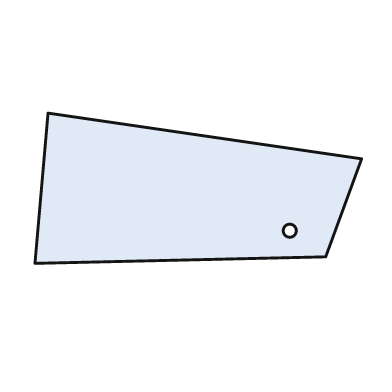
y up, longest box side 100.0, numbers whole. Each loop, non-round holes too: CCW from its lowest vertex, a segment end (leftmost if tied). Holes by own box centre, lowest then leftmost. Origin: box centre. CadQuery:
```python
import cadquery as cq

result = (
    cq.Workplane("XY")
    .moveTo(-50.0, -23.0)
    .lineTo(39.0, -21.0)
    .lineTo(50.0, 9.0)
    .lineTo(-46.0, 23.0)
    .close()
    .moveTo(28.0, -13.0)
    .circle(2.0)
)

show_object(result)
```